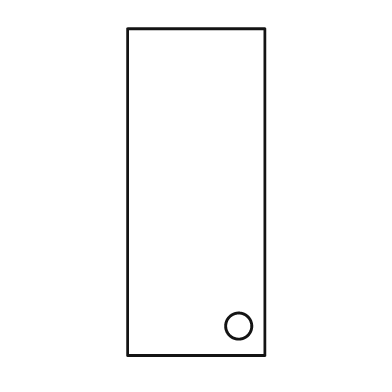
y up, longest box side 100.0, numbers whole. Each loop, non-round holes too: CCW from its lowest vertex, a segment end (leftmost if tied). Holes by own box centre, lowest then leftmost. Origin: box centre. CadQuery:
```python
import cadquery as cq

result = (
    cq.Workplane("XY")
    .moveTo(-21.0, -50.0)
    .lineTo(21.0, -50.0)
    .lineTo(21.0, 50.0)
    .lineTo(-21.0, 50.0)
    .close()
    .moveTo(13.0, -41.0)
    .circle(4.0)
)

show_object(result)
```